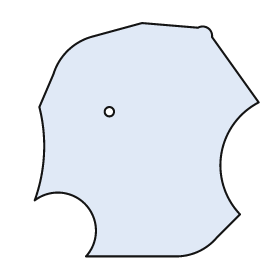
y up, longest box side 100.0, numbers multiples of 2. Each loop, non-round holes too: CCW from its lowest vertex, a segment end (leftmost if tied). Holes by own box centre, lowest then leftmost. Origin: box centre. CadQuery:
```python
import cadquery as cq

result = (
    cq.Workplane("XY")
    .moveTo(-26.0, -50.0)
    .lineTo(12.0, -50.0)
    .threePointArc((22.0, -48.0), (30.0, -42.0))
    .lineTo(40.0, -32.0)
    .threePointArc((32.0, -6.0), (48.0, 16.0))
    .lineTo(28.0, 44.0)
    .threePointArc((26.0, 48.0), (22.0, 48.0))
    .lineTo(-2.0, 50.0)
    .lineTo(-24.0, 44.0)
    .threePointArc((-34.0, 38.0), (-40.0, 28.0))
    .lineTo(-46.0, 14.0)
    .threePointArc((-44.0, -6.0), (-48.0, -26.0))
    .threePointArc((-26.0, -28.0), (-26.0, -50.0))
    .close()
    .moveTo(-16.0, 12.0)
    .circle(2.0)
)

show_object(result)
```